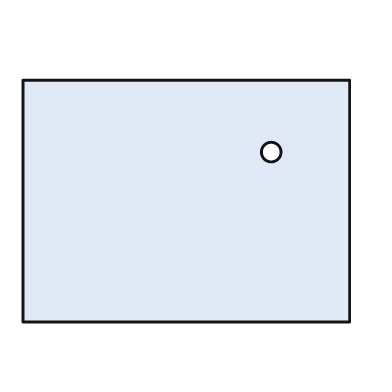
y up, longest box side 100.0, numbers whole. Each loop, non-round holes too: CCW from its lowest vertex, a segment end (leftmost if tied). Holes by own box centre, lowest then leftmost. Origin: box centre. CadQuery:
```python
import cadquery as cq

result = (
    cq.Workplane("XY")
    .moveTo(-50.0, -37.0)
    .lineTo(50.0, -37.0)
    .lineTo(50.0, 37.0)
    .lineTo(-50.0, 37.0)
    .close()
    .moveTo(26.0, 15.0)
    .circle(3.0)
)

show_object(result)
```